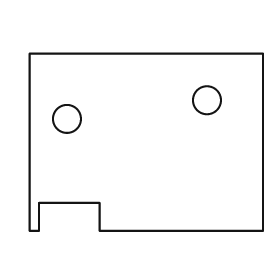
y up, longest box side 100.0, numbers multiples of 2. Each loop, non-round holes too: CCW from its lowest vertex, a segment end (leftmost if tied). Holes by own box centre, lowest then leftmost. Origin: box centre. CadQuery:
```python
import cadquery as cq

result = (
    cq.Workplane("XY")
    .moveTo(-50.0, -38.0)
    .lineTo(-46.0, -38.0)
    .lineTo(-46.0, -26.0)
    .lineTo(-20.0, -26.0)
    .lineTo(-20.0, -38.0)
    .lineTo(50.0, -38.0)
    .lineTo(50.0, 38.0)
    .lineTo(-50.0, 38.0)
    .close()
    .moveTo(-34.0, 10.0)
    .circle(6.0)
    .moveTo(26.0, 18.0)
    .circle(6.0)
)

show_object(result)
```